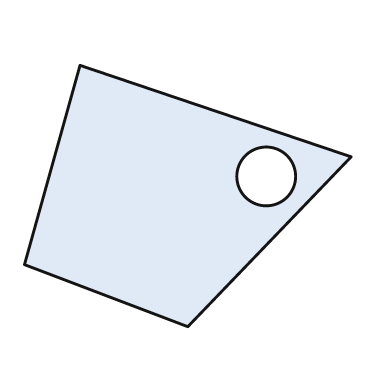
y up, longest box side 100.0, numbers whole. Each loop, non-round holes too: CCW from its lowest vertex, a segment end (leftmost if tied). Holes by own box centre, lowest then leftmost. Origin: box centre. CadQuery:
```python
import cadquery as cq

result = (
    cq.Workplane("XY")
    .moveTo(0.0, -40.0)
    .lineTo(50.0, 12.0)
    .lineTo(-33.0, 40.0)
    .lineTo(-50.0, -21.0)
    .close()
    .moveTo(24.0, 6.0)
    .circle(9.0)
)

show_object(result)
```